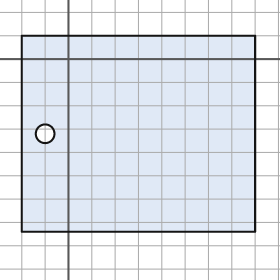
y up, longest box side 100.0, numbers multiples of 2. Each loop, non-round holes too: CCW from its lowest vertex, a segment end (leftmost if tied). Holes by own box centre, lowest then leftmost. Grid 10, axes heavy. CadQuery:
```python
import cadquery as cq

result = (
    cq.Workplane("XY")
    .moveTo(-20.0, -74.0)
    .lineTo(80.0, -74.0)
    .lineTo(80.0, 10.0)
    .lineTo(-20.0, 10.0)
    .close()
    .moveTo(-10.0, -32.0)
    .circle(4.0)
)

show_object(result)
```